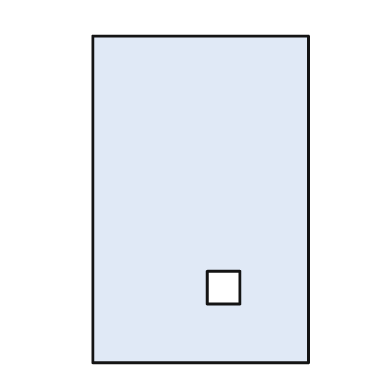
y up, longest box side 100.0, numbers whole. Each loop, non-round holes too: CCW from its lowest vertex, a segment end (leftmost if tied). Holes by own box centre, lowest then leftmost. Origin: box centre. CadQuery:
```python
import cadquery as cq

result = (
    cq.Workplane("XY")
    .moveTo(-33.0, -50.0)
    .lineTo(33.0, -50.0)
    .lineTo(33.0, 50.0)
    .lineTo(-33.0, 50.0)
    .close()
    .moveTo(2.0, -32.0)
    .lineTo(12.0, -32.0)
    .lineTo(12.0, -22.0)
    .lineTo(2.0, -22.0)
    .close()
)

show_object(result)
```